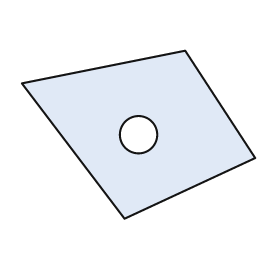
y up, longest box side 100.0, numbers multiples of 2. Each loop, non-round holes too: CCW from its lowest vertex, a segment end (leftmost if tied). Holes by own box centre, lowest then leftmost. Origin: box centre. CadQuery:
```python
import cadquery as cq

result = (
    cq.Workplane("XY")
    .moveTo(-6.0, -36.0)
    .lineTo(50.0, -10.0)
    .lineTo(20.0, 36.0)
    .lineTo(-50.0, 22.0)
    .close()
    .moveTo(0.0, 0.0)
    .circle(8.0)
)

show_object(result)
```